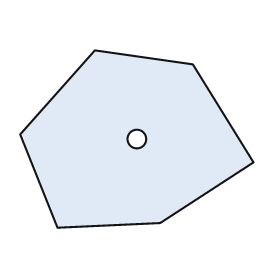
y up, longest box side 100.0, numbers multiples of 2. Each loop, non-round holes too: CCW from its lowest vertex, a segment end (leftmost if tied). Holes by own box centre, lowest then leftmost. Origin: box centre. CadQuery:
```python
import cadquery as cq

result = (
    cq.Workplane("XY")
    .moveTo(-34.0, -38.0)
    .lineTo(10.0, -36.0)
    .lineTo(50.0, -10.0)
    .lineTo(24.0, 32.0)
    .lineTo(-18.0, 38.0)
    .lineTo(-50.0, 2.0)
    .close()
    .moveTo(0.0, 0.0)
    .circle(4.0)
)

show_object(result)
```